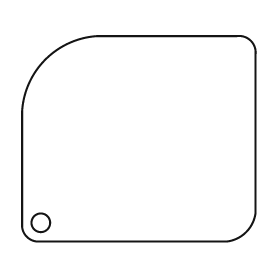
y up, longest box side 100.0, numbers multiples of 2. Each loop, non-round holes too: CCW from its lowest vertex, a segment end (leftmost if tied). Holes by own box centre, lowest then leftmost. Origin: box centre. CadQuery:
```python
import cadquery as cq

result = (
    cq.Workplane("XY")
    .moveTo(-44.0, -44.0)
    .lineTo(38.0, -44.0)
    .threePointArc((46.0, -40.0), (50.0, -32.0))
    .lineTo(50.0, 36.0)
    .threePointArc((48.0, 42.0), (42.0, 44.0))
    .lineTo(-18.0, 44.0)
    .threePointArc((-40.0, 34.0), (-50.0, 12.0))
    .lineTo(-50.0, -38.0)
    .threePointArc((-48.0, -42.0), (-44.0, -44.0))
    .close()
    .moveTo(-42.0, -36.0)
    .circle(4.0)
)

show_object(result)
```